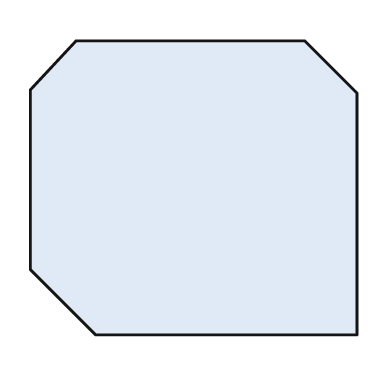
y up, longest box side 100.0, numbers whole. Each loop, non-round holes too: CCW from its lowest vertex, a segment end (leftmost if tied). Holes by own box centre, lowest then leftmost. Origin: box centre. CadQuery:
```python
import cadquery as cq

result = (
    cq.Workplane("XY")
    .moveTo(-30.0, -45.0)
    .lineTo(50.0, -45.0)
    .lineTo(50.0, 29.0)
    .lineTo(34.0, 45.0)
    .lineTo(-36.0, 45.0)
    .lineTo(-50.0, 30.0)
    .lineTo(-50.0, -25.0)
    .close()
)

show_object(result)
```